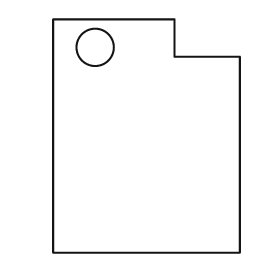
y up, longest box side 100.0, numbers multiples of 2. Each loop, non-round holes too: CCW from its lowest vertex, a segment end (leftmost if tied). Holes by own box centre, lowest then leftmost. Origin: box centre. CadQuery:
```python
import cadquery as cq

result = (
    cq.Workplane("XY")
    .moveTo(-40.0, -50.0)
    .lineTo(40.0, -50.0)
    .lineTo(40.0, 34.0)
    .lineTo(12.0, 34.0)
    .lineTo(12.0, 50.0)
    .lineTo(-40.0, 50.0)
    .close()
    .moveTo(-22.0, 38.0)
    .circle(8.0)
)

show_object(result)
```